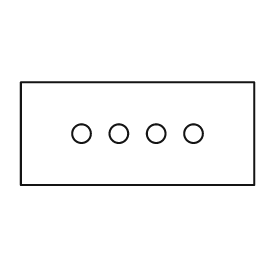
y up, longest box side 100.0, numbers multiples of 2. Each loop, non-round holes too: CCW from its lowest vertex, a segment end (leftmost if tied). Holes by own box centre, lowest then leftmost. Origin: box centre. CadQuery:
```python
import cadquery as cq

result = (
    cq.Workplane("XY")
    .moveTo(-50.0, -22.0)
    .lineTo(50.0, -22.0)
    .lineTo(50.0, 22.0)
    .lineTo(-50.0, 22.0)
    .close()
    .moveTo(-24.0, 0.0)
    .circle(4.0)
    .moveTo(-8.0, 0.0)
    .circle(4.0)
    .moveTo(8.0, 0.0)
    .circle(4.0)
    .moveTo(24.0, 0.0)
    .circle(4.0)
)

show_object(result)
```